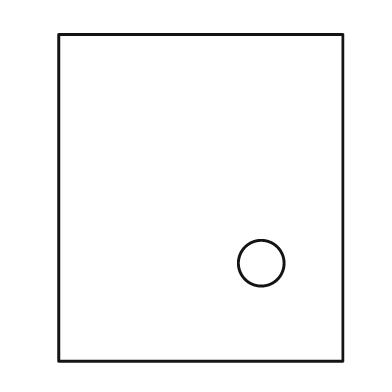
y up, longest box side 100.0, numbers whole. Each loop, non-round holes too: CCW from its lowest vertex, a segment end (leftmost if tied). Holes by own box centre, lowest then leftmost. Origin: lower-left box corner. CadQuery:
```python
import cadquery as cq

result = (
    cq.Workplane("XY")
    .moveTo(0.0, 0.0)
    .lineTo(87.0, 0.0)
    .lineTo(87.0, 100.0)
    .lineTo(0.0, 100.0)
    .close()
    .moveTo(62.0, 30.0)
    .circle(7.0)
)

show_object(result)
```